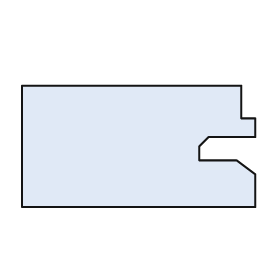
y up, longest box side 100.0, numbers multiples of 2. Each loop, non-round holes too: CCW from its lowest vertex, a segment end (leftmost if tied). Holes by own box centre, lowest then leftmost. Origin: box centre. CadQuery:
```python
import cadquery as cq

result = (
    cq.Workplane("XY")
    .moveTo(-50.0, -26.0)
    .lineTo(50.0, -26.0)
    .lineTo(50.0, -12.0)
    .lineTo(42.0, -6.0)
    .lineTo(26.0, -6.0)
    .lineTo(26.0, 0.0)
    .lineTo(30.0, 4.0)
    .lineTo(50.0, 4.0)
    .lineTo(50.0, 12.0)
    .lineTo(44.0, 12.0)
    .lineTo(44.0, 26.0)
    .lineTo(-50.0, 26.0)
    .close()
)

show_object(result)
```